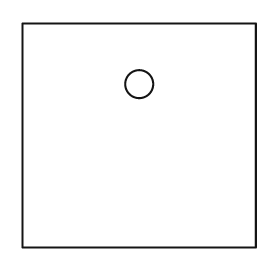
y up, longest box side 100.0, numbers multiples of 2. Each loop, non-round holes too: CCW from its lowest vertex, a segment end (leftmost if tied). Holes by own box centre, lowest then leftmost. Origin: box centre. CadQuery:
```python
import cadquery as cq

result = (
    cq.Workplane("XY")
    .moveTo(-50.0, -48.0)
    .lineTo(50.0, -48.0)
    .lineTo(50.0, 48.0)
    .lineTo(-50.0, 48.0)
    .close()
    .moveTo(0.0, 22.0)
    .circle(6.0)
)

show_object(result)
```